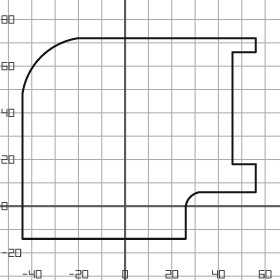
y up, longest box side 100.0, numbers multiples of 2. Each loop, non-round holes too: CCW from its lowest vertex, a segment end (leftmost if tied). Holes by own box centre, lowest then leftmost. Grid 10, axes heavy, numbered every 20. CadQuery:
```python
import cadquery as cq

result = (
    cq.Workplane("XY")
    .moveTo(-44.0, -14.0)
    .lineTo(26.0, -14.0)
    .lineTo(26.0, 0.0)
    .threePointArc((28.0, 4.0), (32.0, 6.0))
    .lineTo(56.0, 6.0)
    .lineTo(56.0, 18.0)
    .lineTo(46.0, 18.0)
    .lineTo(46.0, 66.0)
    .lineTo(56.0, 66.0)
    .lineTo(56.0, 72.0)
    .lineTo(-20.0, 72.0)
    .threePointArc((-36.0, 64.0), (-44.0, 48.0))
    .close()
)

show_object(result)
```